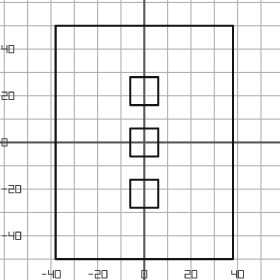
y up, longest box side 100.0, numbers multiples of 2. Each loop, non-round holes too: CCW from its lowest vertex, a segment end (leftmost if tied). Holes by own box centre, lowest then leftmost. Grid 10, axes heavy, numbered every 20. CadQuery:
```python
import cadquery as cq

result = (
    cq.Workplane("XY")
    .moveTo(-38.0, -50.0)
    .lineTo(38.0, -50.0)
    .lineTo(38.0, 50.0)
    .lineTo(-38.0, 50.0)
    .close()
    .moveTo(-6.0, -28.0)
    .lineTo(6.0, -28.0)
    .lineTo(6.0, -16.0)
    .lineTo(-6.0, -16.0)
    .close()
    .moveTo(-6.0, -6.0)
    .lineTo(6.0, -6.0)
    .lineTo(6.0, 6.0)
    .lineTo(-6.0, 6.0)
    .close()
    .moveTo(-6.0, 16.0)
    .lineTo(6.0, 16.0)
    .lineTo(6.0, 28.0)
    .lineTo(-6.0, 28.0)
    .close()
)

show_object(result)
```